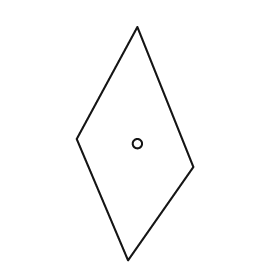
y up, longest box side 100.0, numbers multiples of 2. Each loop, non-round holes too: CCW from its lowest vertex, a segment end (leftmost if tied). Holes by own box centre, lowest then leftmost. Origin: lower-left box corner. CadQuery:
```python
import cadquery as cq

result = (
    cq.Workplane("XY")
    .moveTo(22.0, 0.0)
    .lineTo(50.0, 40.0)
    .lineTo(26.0, 100.0)
    .lineTo(0.0, 52.0)
    .close()
    .moveTo(26.0, 50.0)
    .circle(2.0)
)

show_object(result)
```